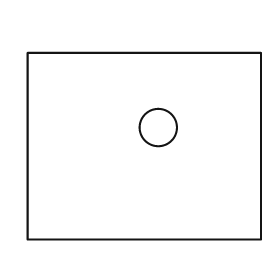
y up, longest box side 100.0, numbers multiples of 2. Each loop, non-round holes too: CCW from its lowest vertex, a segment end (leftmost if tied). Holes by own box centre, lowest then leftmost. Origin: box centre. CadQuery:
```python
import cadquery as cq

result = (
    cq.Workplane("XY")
    .moveTo(-50.0, -40.0)
    .lineTo(50.0, -40.0)
    .lineTo(50.0, 40.0)
    .lineTo(-50.0, 40.0)
    .close()
    .moveTo(6.0, 8.0)
    .circle(8.0)
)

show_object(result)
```